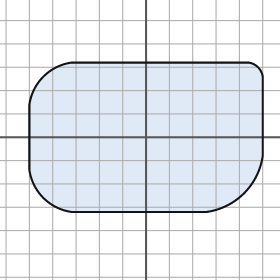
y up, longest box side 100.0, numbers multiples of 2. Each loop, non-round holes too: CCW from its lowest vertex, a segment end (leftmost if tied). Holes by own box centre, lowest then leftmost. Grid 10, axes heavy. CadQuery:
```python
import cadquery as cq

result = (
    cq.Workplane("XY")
    .moveTo(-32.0, -32.0)
    .lineTo(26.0, -32.0)
    .threePointArc((42.0, -24.0), (50.0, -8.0))
    .lineTo(50.0, 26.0)
    .threePointArc((48.0, 30.0), (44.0, 32.0))
    .lineTo(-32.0, 32.0)
    .threePointArc((-44.0, 26.0), (-50.0, 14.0))
    .lineTo(-50.0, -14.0)
    .threePointArc((-44.0, -26.0), (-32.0, -32.0))
    .close()
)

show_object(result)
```